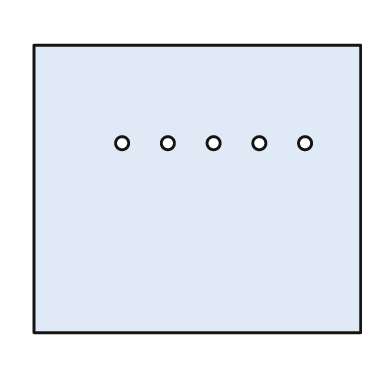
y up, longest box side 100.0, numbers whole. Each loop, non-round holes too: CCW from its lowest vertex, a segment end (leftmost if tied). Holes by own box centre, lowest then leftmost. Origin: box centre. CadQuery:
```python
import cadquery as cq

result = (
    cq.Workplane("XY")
    .moveTo(-50.0, -44.0)
    .lineTo(50.0, -44.0)
    .lineTo(50.0, 44.0)
    .lineTo(-50.0, 44.0)
    .close()
    .moveTo(-23.0, 14.0)
    .circle(2.0)
    .moveTo(-9.0, 14.0)
    .circle(2.0)
    .moveTo(5.0, 14.0)
    .circle(2.0)
    .moveTo(19.0, 14.0)
    .circle(2.0)
    .moveTo(33.0, 14.0)
    .circle(2.0)
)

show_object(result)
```